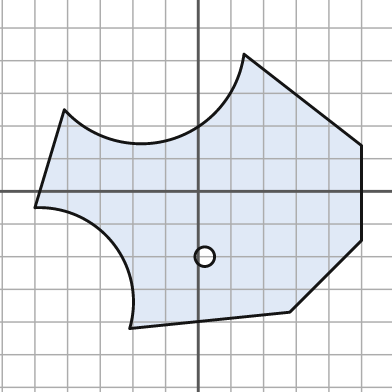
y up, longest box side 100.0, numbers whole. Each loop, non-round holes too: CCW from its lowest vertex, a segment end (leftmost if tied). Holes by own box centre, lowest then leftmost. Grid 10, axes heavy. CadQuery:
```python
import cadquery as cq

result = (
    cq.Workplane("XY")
    .moveTo(-21.0, -42.0)
    .lineTo(28.0, -37.0)
    .lineTo(50.0, -15.0)
    .lineTo(50.0, 14.0)
    .lineTo(14.0, 42.0)
    .threePointArc((-8.0, 16.0), (-41.0, 25.0))
    .lineTo(-50.0, -5.0)
    .threePointArc((-26.0, -16.0), (-21.0, -42.0))
    .close()
    .moveTo(2.0, -20.0)
    .circle(3.0)
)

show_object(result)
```